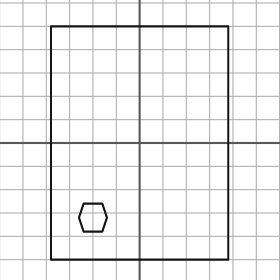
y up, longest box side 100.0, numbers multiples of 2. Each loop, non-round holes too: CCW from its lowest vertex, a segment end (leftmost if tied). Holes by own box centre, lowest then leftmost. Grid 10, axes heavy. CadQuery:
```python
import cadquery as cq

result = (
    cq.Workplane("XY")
    .moveTo(-38.0, -50.0)
    .lineTo(38.0, -50.0)
    .lineTo(38.0, 50.0)
    .lineTo(-38.0, 50.0)
    .close()
    .moveTo(-24.0, -38.0)
    .lineTo(-16.0, -38.0)
    .lineTo(-14.0, -32.0)
    .lineTo(-16.0, -26.0)
    .lineTo(-24.0, -26.0)
    .lineTo(-26.0, -32.0)
    .close()
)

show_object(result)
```